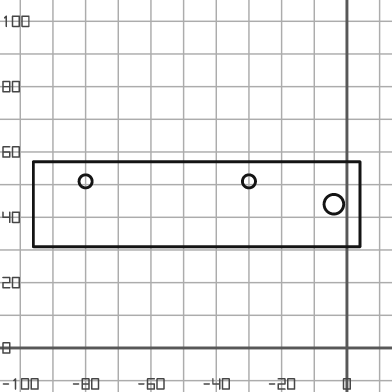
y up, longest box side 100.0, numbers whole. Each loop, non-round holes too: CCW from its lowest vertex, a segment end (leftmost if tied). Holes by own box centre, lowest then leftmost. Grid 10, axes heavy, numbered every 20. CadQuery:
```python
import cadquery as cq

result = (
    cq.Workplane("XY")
    .moveTo(-96.0, 31.0)
    .lineTo(4.0, 31.0)
    .lineTo(4.0, 57.0)
    .lineTo(-96.0, 57.0)
    .close()
    .moveTo(-4.0, 44.0)
    .circle(3.0)
    .moveTo(-80.0, 51.0)
    .circle(2.0)
    .moveTo(-30.0, 51.0)
    .circle(2.0)
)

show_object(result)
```